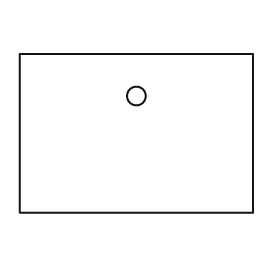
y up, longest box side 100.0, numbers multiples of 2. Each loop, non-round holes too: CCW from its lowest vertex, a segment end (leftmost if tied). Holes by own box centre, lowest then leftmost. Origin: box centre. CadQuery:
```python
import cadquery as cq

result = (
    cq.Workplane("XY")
    .moveTo(-50.0, -34.0)
    .lineTo(50.0, -34.0)
    .lineTo(50.0, 34.0)
    .lineTo(-50.0, 34.0)
    .close()
    .moveTo(0.0, 16.0)
    .circle(4.0)
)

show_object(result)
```